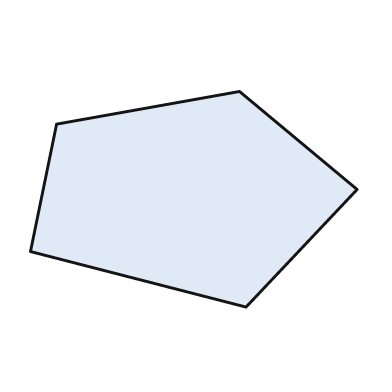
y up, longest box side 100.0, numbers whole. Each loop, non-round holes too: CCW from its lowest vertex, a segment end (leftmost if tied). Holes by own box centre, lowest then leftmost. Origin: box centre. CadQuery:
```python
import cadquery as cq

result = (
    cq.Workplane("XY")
    .moveTo(16.0, -33.0)
    .lineTo(50.0, 3.0)
    .lineTo(14.0, 33.0)
    .lineTo(-42.0, 23.0)
    .lineTo(-50.0, -16.0)
    .close()
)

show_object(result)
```